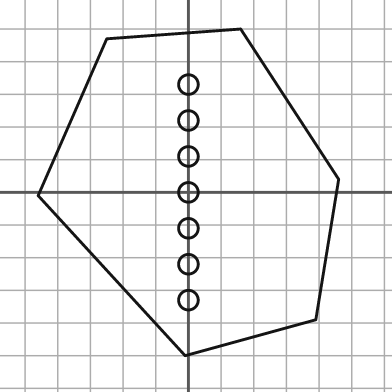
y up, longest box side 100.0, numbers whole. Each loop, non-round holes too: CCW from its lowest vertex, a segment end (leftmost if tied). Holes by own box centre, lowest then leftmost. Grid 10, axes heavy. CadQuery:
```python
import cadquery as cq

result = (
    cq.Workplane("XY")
    .moveTo(-1.0, -50.0)
    .lineTo(39.0, -39.0)
    .lineTo(46.0, 4.0)
    .lineTo(16.0, 50.0)
    .lineTo(-25.0, 47.0)
    .lineTo(-46.0, -1.0)
    .close()
    .moveTo(0.0, -33.0)
    .circle(3.0)
    .moveTo(0.0, -22.0)
    .circle(3.0)
    .moveTo(0.0, -11.0)
    .circle(3.0)
    .moveTo(0.0, 0.0)
    .circle(3.0)
    .moveTo(0.0, 11.0)
    .circle(3.0)
    .moveTo(0.0, 22.0)
    .circle(3.0)
    .moveTo(0.0, 33.0)
    .circle(3.0)
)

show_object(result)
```